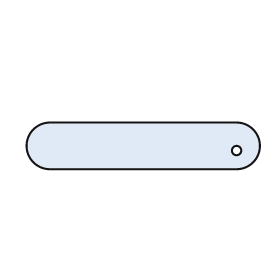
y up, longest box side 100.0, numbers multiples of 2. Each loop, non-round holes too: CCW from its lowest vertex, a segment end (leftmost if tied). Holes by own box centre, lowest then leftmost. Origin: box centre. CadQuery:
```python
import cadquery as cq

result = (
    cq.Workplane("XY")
    .moveTo(-40.0, -10.0)
    .lineTo(40.0, -10.0)
    .threePointArc((50.0, 0.0), (40.0, 10.0))
    .lineTo(-40.0, 10.0)
    .threePointArc((-50.0, 0.0), (-40.0, -10.0))
    .close()
    .moveTo(40.0, -2.0)
    .circle(2.0)
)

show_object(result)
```